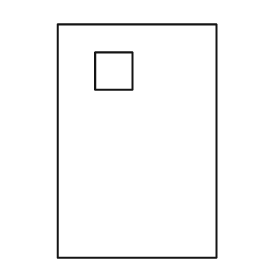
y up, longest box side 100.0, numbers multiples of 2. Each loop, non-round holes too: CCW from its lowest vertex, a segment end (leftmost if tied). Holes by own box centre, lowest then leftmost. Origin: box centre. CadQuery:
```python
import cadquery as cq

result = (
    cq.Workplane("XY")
    .moveTo(-34.0, -50.0)
    .lineTo(34.0, -50.0)
    .lineTo(34.0, 50.0)
    .lineTo(-34.0, 50.0)
    .close()
    .moveTo(-18.0, 22.0)
    .lineTo(-2.0, 22.0)
    .lineTo(-2.0, 38.0)
    .lineTo(-18.0, 38.0)
    .close()
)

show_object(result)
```